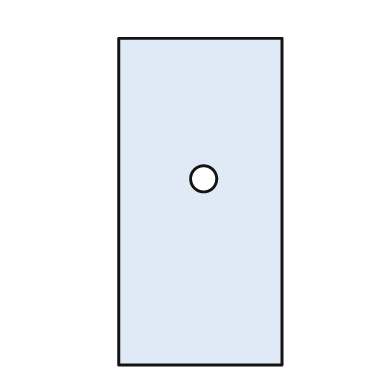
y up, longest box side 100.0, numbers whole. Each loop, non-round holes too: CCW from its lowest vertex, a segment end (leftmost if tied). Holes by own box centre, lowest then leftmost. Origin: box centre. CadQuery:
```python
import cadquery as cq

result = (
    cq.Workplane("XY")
    .moveTo(-25.0, -50.0)
    .lineTo(25.0, -50.0)
    .lineTo(25.0, 50.0)
    .lineTo(-25.0, 50.0)
    .close()
    .moveTo(1.0, 7.0)
    .circle(4.0)
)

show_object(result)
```